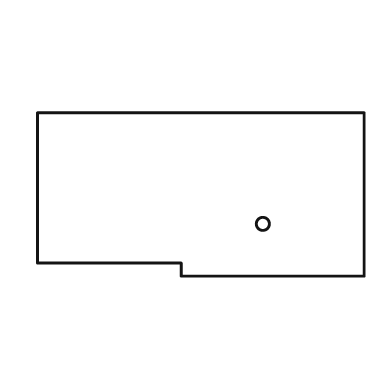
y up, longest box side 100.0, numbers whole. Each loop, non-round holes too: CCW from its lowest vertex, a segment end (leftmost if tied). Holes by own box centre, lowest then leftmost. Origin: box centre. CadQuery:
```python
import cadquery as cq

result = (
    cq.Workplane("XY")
    .moveTo(-6.0, -25.0)
    .lineTo(50.0, -25.0)
    .lineTo(50.0, 25.0)
    .lineTo(-50.0, 25.0)
    .lineTo(-50.0, -21.0)
    .lineTo(-6.0, -21.0)
    .close()
    .moveTo(19.0, -9.0)
    .circle(2.0)
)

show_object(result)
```